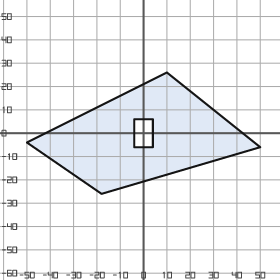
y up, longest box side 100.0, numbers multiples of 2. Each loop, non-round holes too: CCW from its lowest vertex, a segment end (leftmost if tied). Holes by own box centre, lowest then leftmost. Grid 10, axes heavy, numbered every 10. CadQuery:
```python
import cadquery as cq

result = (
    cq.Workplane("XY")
    .moveTo(-18.0, -26.0)
    .lineTo(50.0, -6.0)
    .lineTo(10.0, 26.0)
    .lineTo(-50.0, -4.0)
    .close()
    .moveTo(-4.0, -6.0)
    .lineTo(4.0, -6.0)
    .lineTo(4.0, 6.0)
    .lineTo(-4.0, 6.0)
    .close()
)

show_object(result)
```